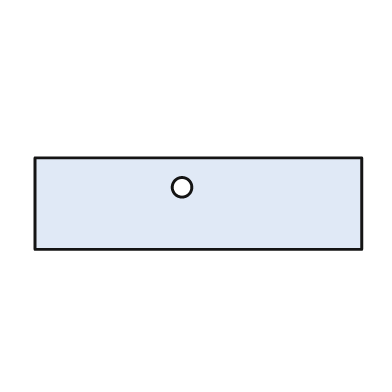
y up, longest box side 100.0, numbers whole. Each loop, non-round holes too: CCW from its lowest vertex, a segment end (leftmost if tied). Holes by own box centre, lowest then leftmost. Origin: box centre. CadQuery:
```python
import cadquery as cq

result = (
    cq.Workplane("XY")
    .moveTo(-50.0, -14.0)
    .lineTo(50.0, -14.0)
    .lineTo(50.0, 14.0)
    .lineTo(-50.0, 14.0)
    .close()
    .moveTo(-5.0, 5.0)
    .circle(3.0)
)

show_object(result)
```